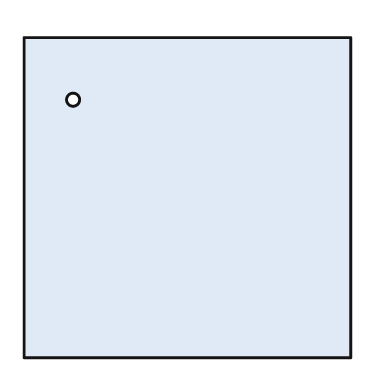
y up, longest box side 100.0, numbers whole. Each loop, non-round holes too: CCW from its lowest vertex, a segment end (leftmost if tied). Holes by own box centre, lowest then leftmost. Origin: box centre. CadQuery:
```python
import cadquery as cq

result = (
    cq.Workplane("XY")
    .moveTo(-50.0, -49.0)
    .lineTo(50.0, -49.0)
    .lineTo(50.0, 49.0)
    .lineTo(-50.0, 49.0)
    .close()
    .moveTo(-35.0, 30.0)
    .circle(2.0)
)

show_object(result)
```